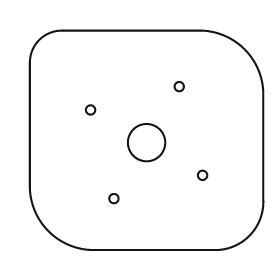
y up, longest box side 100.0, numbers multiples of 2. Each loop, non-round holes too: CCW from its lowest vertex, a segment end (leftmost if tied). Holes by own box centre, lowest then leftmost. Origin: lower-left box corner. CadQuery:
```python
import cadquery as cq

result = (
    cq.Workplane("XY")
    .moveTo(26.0, 0.0)
    .lineTo(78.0, 0.0)
    .threePointArc((94.0, 6.0), (100.0, 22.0))
    .lineTo(100.0, 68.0)
    .threePointArc((92.0, 86.0), (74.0, 94.0))
    .lineTo(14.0, 94.0)
    .threePointArc((4.0, 90.0), (0.0, 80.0))
    .lineTo(0.0, 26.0)
    .threePointArc((8.0, 8.0), (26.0, 0.0))
    .close()
    .moveTo(36.0, 22.0)
    .circle(2.0)
    .moveTo(74.0, 32.0)
    .circle(2.0)
    .moveTo(50.0, 46.0)
    .circle(8.0)
    .moveTo(26.0, 60.0)
    .circle(2.0)
    .moveTo(64.0, 70.0)
    .circle(2.0)
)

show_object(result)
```